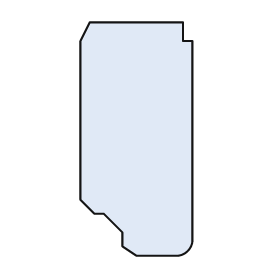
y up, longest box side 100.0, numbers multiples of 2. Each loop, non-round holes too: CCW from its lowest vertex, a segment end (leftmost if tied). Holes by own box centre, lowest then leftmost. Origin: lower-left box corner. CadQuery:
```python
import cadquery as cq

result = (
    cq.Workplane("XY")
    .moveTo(24.0, 0.0)
    .lineTo(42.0, 0.0)
    .threePointArc((46.0, 2.0), (48.0, 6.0))
    .lineTo(48.0, 92.0)
    .lineTo(44.0, 92.0)
    .lineTo(44.0, 100.0)
    .lineTo(4.0, 100.0)
    .lineTo(0.0, 92.0)
    .lineTo(0.0, 24.0)
    .lineTo(6.0, 18.0)
    .lineTo(10.0, 18.0)
    .lineTo(18.0, 10.0)
    .lineTo(18.0, 4.0)
    .close()
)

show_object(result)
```